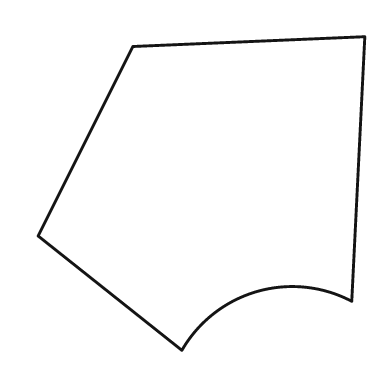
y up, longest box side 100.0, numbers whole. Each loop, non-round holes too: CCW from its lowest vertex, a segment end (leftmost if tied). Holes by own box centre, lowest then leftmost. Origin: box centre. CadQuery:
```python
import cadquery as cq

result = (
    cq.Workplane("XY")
    .moveTo(-6.0, -48.0)
    .threePointArc((17.0, -30.0), (46.0, -33.0))
    .lineTo(50.0, 48.0)
    .lineTo(-21.0, 45.0)
    .lineTo(-50.0, -13.0)
    .close()
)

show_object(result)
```